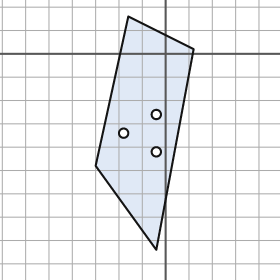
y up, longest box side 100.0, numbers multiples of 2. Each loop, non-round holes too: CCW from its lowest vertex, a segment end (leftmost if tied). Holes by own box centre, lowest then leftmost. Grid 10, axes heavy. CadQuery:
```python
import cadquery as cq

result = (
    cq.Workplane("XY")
    .moveTo(-4.0, -84.0)
    .lineTo(12.0, 2.0)
    .lineTo(-16.0, 16.0)
    .lineTo(-30.0, -48.0)
    .close()
    .moveTo(-4.0, -42.0)
    .circle(2.0)
    .moveTo(-18.0, -34.0)
    .circle(2.0)
    .moveTo(-4.0, -26.0)
    .circle(2.0)
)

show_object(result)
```